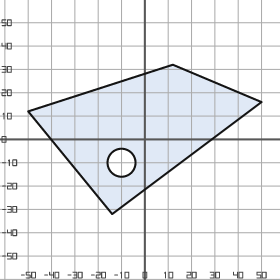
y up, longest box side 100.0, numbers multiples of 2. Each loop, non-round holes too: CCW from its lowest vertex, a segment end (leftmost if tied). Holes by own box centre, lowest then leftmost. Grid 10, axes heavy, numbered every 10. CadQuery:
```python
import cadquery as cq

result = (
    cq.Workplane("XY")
    .moveTo(-14.0, -32.0)
    .lineTo(50.0, 16.0)
    .lineTo(12.0, 32.0)
    .lineTo(-50.0, 12.0)
    .close()
    .moveTo(-10.0, -10.0)
    .circle(6.0)
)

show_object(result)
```